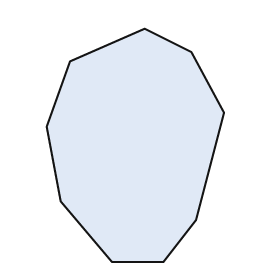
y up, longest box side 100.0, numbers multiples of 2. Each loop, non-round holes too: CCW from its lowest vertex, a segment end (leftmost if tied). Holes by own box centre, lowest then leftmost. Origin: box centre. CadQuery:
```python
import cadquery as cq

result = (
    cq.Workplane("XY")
    .moveTo(-10.0, -50.0)
    .lineTo(12.0, -50.0)
    .lineTo(26.0, -32.0)
    .lineTo(38.0, 14.0)
    .lineTo(24.0, 40.0)
    .lineTo(4.0, 50.0)
    .lineTo(-28.0, 36.0)
    .lineTo(-38.0, 8.0)
    .lineTo(-32.0, -24.0)
    .close()
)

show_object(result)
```